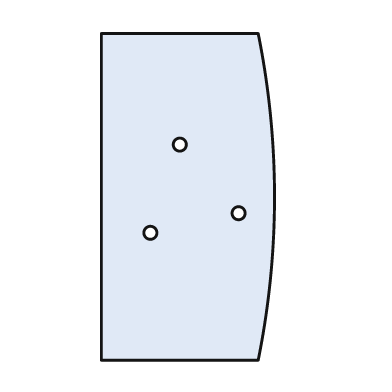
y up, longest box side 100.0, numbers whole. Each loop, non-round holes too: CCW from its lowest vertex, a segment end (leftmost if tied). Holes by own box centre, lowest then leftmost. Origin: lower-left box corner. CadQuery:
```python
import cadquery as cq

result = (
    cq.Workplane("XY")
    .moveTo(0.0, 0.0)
    .lineTo(48.0, 0.0)
    .threePointArc((53.0, 50.0), (48.0, 100.0))
    .lineTo(0.0, 100.0)
    .close()
    .moveTo(15.0, 39.0)
    .circle(2.0)
    .moveTo(42.0, 45.0)
    .circle(2.0)
    .moveTo(24.0, 66.0)
    .circle(2.0)
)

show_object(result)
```